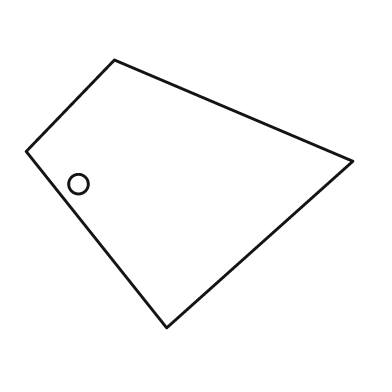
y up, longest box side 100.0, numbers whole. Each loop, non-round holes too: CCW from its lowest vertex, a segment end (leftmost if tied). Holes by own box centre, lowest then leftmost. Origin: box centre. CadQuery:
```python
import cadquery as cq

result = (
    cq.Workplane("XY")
    .moveTo(-7.0, -41.0)
    .lineTo(50.0, 10.0)
    .lineTo(-23.0, 41.0)
    .lineTo(-50.0, 13.0)
    .close()
    .moveTo(-34.0, 3.0)
    .circle(3.0)
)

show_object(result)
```